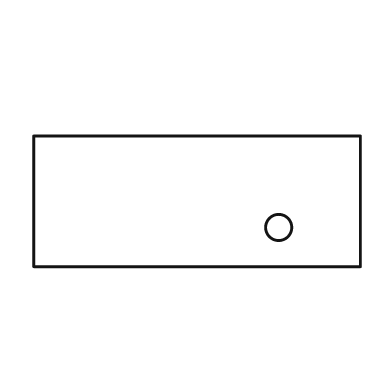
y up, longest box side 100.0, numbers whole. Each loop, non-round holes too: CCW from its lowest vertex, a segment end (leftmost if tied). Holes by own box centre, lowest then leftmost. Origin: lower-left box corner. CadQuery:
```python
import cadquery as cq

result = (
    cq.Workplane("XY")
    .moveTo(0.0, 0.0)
    .lineTo(100.0, 0.0)
    .lineTo(100.0, 40.0)
    .lineTo(0.0, 40.0)
    .close()
    .moveTo(75.0, 12.0)
    .circle(4.0)
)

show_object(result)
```